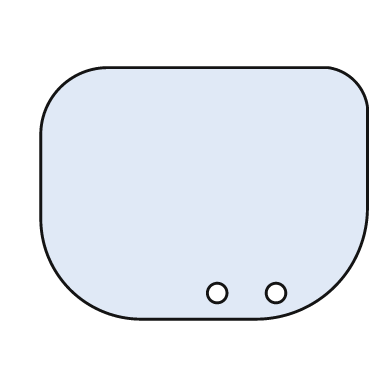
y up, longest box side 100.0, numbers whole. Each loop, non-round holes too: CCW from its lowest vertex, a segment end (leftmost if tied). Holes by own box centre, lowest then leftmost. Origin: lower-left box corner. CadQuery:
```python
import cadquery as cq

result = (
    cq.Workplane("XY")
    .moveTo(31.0, 0.0)
    .lineTo(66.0, 0.0)
    .threePointArc((90.0, 10.0), (100.0, 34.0))
    .lineTo(100.0, 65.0)
    .threePointArc((96.0, 73.0), (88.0, 77.0))
    .lineTo(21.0, 77.0)
    .threePointArc((6.0, 71.0), (0.0, 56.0))
    .lineTo(0.0, 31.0)
    .threePointArc((9.0, 9.0), (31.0, 0.0))
    .close()
    .moveTo(54.0, 8.0)
    .circle(3.0)
    .moveTo(72.0, 8.0)
    .circle(3.0)
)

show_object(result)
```